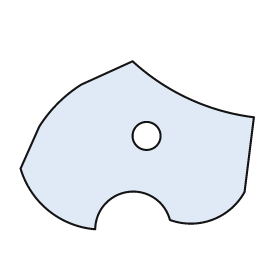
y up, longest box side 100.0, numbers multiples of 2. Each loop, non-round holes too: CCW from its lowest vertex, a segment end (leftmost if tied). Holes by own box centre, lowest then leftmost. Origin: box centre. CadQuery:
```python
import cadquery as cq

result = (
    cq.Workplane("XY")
    .moveTo(-18.0, -36.0)
    .threePointArc((-4.0, -20.0), (14.0, -32.0))
    .threePointArc((32.0, -32.0), (46.0, -20.0))
    .lineTo(50.0, 12.0)
    .threePointArc((22.0, 20.0), (-2.0, 36.0))
    .lineTo(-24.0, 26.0)
    .threePointArc((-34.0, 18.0), (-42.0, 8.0))
    .lineTo(-50.0, -10.0)
    .threePointArc((-38.0, -28.0), (-18.0, -36.0))
    .close()
    .moveTo(4.0, 4.0)
    .circle(6.0)
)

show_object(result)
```